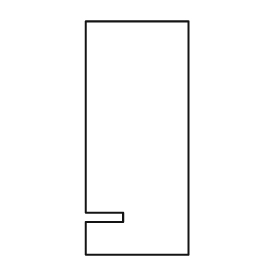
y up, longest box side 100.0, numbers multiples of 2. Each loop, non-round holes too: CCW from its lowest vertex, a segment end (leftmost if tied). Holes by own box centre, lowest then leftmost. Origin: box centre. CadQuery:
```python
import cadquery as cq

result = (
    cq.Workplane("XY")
    .moveTo(-22.0, -50.0)
    .lineTo(22.0, -50.0)
    .lineTo(22.0, 50.0)
    .lineTo(-22.0, 50.0)
    .lineTo(-22.0, -32.0)
    .lineTo(-6.0, -32.0)
    .lineTo(-6.0, -36.0)
    .lineTo(-22.0, -36.0)
    .close()
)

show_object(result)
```